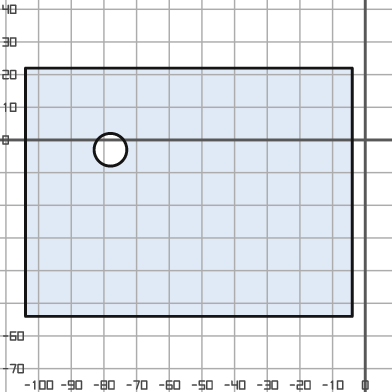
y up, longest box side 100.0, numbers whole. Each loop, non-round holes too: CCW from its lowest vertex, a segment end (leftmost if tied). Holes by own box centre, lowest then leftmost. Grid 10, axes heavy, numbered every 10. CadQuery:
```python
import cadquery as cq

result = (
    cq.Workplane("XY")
    .moveTo(-104.0, -54.0)
    .lineTo(-4.0, -54.0)
    .lineTo(-4.0, 22.0)
    .lineTo(-104.0, 22.0)
    .close()
    .moveTo(-78.0, -3.0)
    .circle(5.0)
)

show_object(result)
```